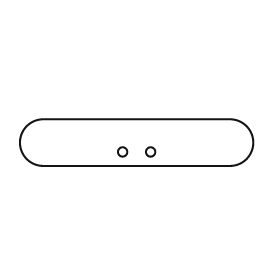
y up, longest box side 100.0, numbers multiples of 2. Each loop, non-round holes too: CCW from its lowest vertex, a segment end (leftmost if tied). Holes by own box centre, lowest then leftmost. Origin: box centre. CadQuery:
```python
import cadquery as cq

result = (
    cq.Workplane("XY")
    .moveTo(-40.0, -10.0)
    .lineTo(40.0, -10.0)
    .threePointArc((50.0, 0.0), (40.0, 10.0))
    .lineTo(-40.0, 10.0)
    .threePointArc((-50.0, 0.0), (-40.0, -10.0))
    .close()
    .moveTo(-6.0, -4.0)
    .circle(2.0)
    .moveTo(6.0, -4.0)
    .circle(2.0)
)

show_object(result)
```